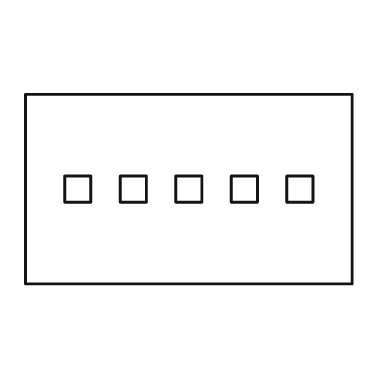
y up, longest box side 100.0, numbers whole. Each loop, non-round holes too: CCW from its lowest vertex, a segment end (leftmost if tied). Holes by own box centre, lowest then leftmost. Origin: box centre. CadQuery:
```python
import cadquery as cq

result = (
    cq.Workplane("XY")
    .moveTo(-50.0, -29.0)
    .lineTo(50.0, -29.0)
    .lineTo(50.0, 29.0)
    .lineTo(-50.0, 29.0)
    .close()
    .moveTo(-38.0, -4.0)
    .lineTo(-30.0, -4.0)
    .lineTo(-30.0, 4.0)
    .lineTo(-38.0, 4.0)
    .close()
    .moveTo(-21.0, -4.0)
    .lineTo(-13.0, -4.0)
    .lineTo(-13.0, 4.0)
    .lineTo(-21.0, 4.0)
    .close()
    .moveTo(-4.0, -4.0)
    .lineTo(4.0, -4.0)
    .lineTo(4.0, 4.0)
    .lineTo(-4.0, 4.0)
    .close()
    .moveTo(13.0, -4.0)
    .lineTo(21.0, -4.0)
    .lineTo(21.0, 4.0)
    .lineTo(13.0, 4.0)
    .close()
    .moveTo(30.0, -4.0)
    .lineTo(38.0, -4.0)
    .lineTo(38.0, 4.0)
    .lineTo(30.0, 4.0)
    .close()
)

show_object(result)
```